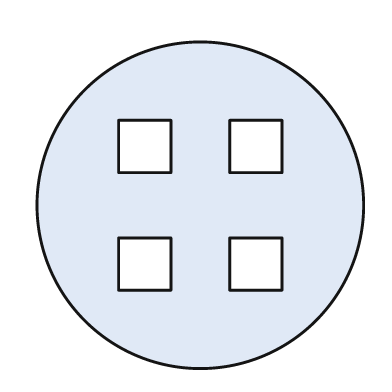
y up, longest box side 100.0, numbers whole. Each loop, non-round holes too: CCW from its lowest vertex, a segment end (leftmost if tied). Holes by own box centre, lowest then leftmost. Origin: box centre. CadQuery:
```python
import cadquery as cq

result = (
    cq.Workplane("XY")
    .moveTo(0.0, 0.0)
    .circle(50.0)
    .moveTo(-25.0, -26.0)
    .lineTo(-9.0, -26.0)
    .lineTo(-9.0, -10.0)
    .lineTo(-25.0, -10.0)
    .close()
    .moveTo(9.0, -26.0)
    .lineTo(25.0, -26.0)
    .lineTo(25.0, -10.0)
    .lineTo(9.0, -10.0)
    .close()
    .moveTo(-25.0, 10.0)
    .lineTo(-9.0, 10.0)
    .lineTo(-9.0, 26.0)
    .lineTo(-25.0, 26.0)
    .close()
    .moveTo(9.0, 10.0)
    .lineTo(25.0, 10.0)
    .lineTo(25.0, 26.0)
    .lineTo(9.0, 26.0)
    .close()
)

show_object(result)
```